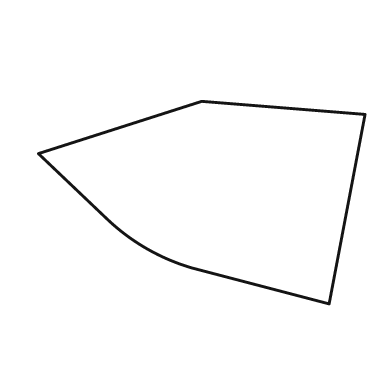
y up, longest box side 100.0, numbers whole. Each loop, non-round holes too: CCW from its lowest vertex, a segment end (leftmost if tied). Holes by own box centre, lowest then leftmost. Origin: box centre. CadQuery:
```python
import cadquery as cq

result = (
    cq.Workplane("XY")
    .moveTo(39.0, -31.0)
    .lineTo(50.0, 27.0)
    .lineTo(0.0, 31.0)
    .lineTo(-50.0, 15.0)
    .lineTo(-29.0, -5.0)
    .threePointArc((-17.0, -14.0), (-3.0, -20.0))
    .close()
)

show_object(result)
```